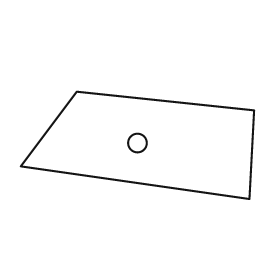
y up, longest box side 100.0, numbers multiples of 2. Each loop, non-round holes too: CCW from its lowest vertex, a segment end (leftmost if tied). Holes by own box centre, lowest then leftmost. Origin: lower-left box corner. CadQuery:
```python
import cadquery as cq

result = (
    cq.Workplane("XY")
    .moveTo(98.0, 0.0)
    .lineTo(100.0, 38.0)
    .lineTo(24.0, 46.0)
    .lineTo(0.0, 14.0)
    .close()
    .moveTo(50.0, 24.0)
    .circle(4.0)
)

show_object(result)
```